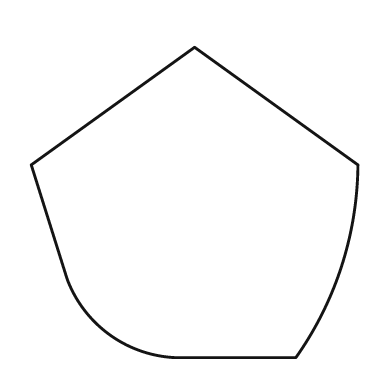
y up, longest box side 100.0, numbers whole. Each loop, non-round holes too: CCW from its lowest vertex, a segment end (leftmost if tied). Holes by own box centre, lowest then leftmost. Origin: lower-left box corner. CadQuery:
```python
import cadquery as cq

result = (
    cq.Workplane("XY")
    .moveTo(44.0, 0.0)
    .lineTo(81.0, 0.0)
    .threePointArc((95.0, 28.0), (100.0, 59.0))
    .lineTo(50.0, 95.0)
    .lineTo(0.0, 59.0)
    .lineTo(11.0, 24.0)
    .threePointArc((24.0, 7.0), (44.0, 0.0))
    .close()
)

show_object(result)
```